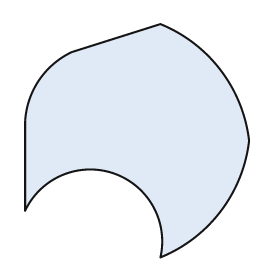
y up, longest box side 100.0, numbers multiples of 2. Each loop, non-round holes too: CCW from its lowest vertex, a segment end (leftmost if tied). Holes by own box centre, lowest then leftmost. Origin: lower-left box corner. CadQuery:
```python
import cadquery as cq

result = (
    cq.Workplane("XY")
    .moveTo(58.0, 0.0)
    .threePointArc((84.0, 20.0), (96.0, 50.0))
    .threePointArc((84.0, 80.0), (58.0, 100.0))
    .lineTo(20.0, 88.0)
    .threePointArc((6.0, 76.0), (0.0, 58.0))
    .lineTo(0.0, 20.0)
    .threePointArc((38.0, 36.0), (58.0, 0.0))
    .close()
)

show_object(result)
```